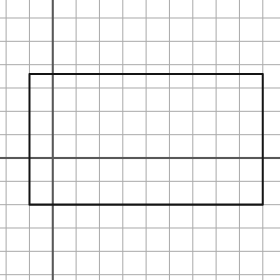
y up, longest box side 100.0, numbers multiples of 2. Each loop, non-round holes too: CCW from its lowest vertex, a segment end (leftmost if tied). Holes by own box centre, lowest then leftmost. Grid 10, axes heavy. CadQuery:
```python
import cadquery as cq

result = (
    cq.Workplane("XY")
    .moveTo(-10.0, -20.0)
    .lineTo(90.0, -20.0)
    .lineTo(90.0, 36.0)
    .lineTo(-10.0, 36.0)
    .close()
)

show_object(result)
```